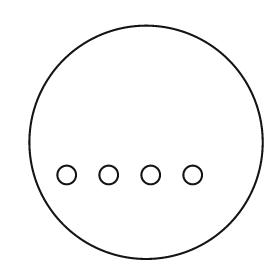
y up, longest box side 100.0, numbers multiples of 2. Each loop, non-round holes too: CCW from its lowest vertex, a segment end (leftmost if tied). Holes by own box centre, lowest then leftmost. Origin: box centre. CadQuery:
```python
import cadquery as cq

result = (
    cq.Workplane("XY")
    .moveTo(0.0, 0.0)
    .circle(50.0)
    .moveTo(-34.0, -14.0)
    .circle(4.0)
    .moveTo(-16.0, -14.0)
    .circle(4.0)
    .moveTo(2.0, -14.0)
    .circle(4.0)
    .moveTo(20.0, -14.0)
    .circle(4.0)
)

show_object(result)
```